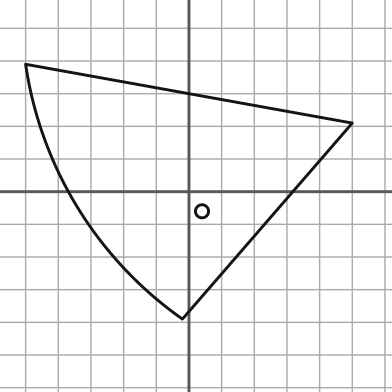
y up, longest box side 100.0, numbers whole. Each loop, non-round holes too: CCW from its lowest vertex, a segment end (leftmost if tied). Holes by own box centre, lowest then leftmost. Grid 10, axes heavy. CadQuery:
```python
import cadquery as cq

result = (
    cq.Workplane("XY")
    .moveTo(-2.0, -39.0)
    .lineTo(50.0, 21.0)
    .lineTo(-50.0, 39.0)
    .threePointArc((-34.0, -5.0), (-2.0, -39.0))
    .close()
    .moveTo(4.0, -6.0)
    .circle(2.0)
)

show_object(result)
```